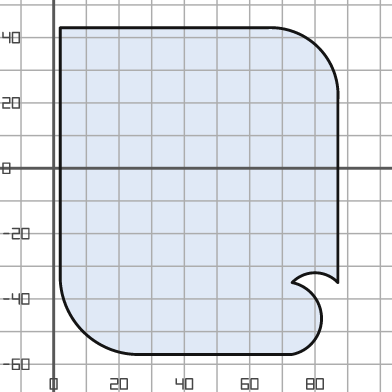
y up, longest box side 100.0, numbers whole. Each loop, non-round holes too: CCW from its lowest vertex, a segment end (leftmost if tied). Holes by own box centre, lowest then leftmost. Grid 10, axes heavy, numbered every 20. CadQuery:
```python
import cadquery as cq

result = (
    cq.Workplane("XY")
    .moveTo(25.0, -57.0)
    .lineTo(73.0, -57.0)
    .threePointArc((82.0, -46.0), (73.0, -35.0))
    .threePointArc((80.0, -32.0), (87.0, -35.0))
    .lineTo(87.0, 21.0)
    .threePointArc((81.0, 37.0), (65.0, 43.0))
    .lineTo(2.0, 43.0)
    .lineTo(2.0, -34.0)
    .threePointArc((9.0, -50.0), (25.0, -57.0))
    .close()
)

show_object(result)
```